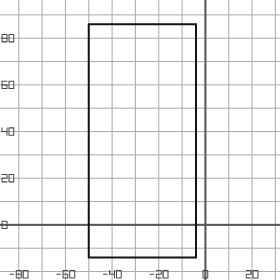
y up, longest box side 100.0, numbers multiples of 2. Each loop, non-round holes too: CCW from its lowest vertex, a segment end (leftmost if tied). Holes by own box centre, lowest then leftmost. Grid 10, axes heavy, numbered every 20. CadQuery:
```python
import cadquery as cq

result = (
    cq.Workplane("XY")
    .moveTo(-50.0, -14.0)
    .lineTo(-4.0, -14.0)
    .lineTo(-4.0, 86.0)
    .lineTo(-50.0, 86.0)
    .close()
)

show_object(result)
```